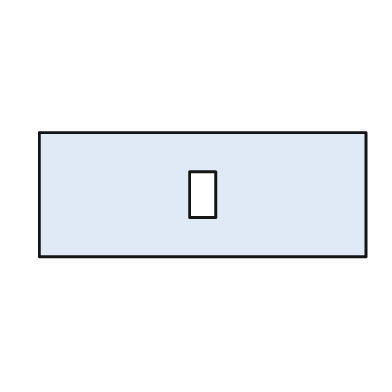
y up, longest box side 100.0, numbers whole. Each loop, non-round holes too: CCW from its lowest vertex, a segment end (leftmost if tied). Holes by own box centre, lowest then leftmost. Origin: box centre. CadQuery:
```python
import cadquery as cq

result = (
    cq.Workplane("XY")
    .moveTo(-50.0, -19.0)
    .lineTo(50.0, -19.0)
    .lineTo(50.0, 19.0)
    .lineTo(-50.0, 19.0)
    .close()
    .moveTo(-4.0, -7.0)
    .lineTo(4.0, -7.0)
    .lineTo(4.0, 7.0)
    .lineTo(-4.0, 7.0)
    .close()
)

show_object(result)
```